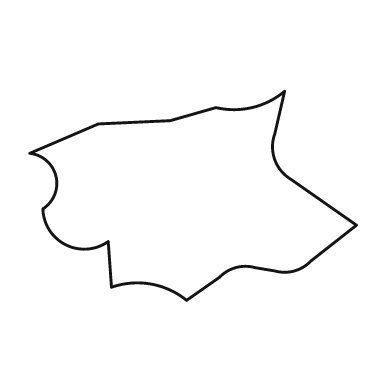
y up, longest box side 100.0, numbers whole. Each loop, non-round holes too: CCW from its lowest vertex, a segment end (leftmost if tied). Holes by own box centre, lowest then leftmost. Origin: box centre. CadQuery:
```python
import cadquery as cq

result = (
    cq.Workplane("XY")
    .moveTo(-2.0, -32.0)
    .lineTo(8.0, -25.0)
    .threePointArc((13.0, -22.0), (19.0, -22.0))
    .lineTo(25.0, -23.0)
    .threePointArc((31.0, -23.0), (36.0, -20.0))
    .lineTo(50.0, -9.0)
    .lineTo(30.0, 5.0)
    .threePointArc((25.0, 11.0), (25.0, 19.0))
    .lineTo(28.0, 32.0)
    .threePointArc((18.0, 27.0), (7.0, 27.0))
    .lineTo(-7.0, 23.0)
    .lineTo(-29.0, 22.0)
    .lineTo(-50.0, 13.0)
    .threePointArc((-42.0, 6.0), (-46.0, -4.0))
    .threePointArc((-39.0, -15.0), (-26.0, -14.0))
    .lineTo(-25.0, -28.0)
    .threePointArc((-13.0, -27.0), (-2.0, -32.0))
    .close()
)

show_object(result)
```